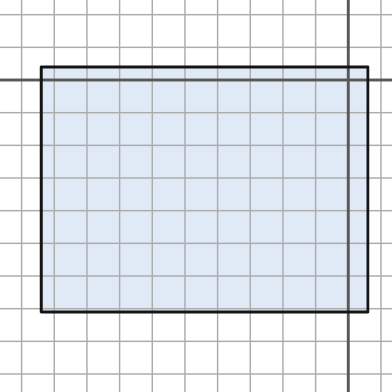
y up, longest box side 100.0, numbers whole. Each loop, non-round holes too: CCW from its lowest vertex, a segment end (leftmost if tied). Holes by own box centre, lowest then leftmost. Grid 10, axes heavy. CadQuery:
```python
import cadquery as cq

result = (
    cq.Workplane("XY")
    .moveTo(-94.0, -71.0)
    .lineTo(6.0, -71.0)
    .lineTo(6.0, 4.0)
    .lineTo(-94.0, 4.0)
    .close()
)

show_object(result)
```